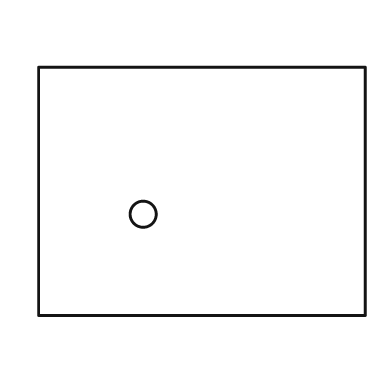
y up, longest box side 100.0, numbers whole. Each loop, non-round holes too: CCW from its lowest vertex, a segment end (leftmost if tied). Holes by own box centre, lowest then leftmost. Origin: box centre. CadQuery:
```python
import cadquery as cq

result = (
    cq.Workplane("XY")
    .moveTo(-50.0, -38.0)
    .lineTo(50.0, -38.0)
    .lineTo(50.0, 38.0)
    .lineTo(-50.0, 38.0)
    .close()
    .moveTo(-18.0, -7.0)
    .circle(4.0)
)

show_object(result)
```